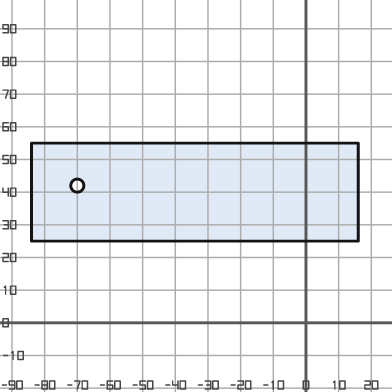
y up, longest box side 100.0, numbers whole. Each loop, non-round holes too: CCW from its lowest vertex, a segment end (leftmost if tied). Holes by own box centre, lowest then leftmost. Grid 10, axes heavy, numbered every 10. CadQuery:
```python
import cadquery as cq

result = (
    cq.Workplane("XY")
    .moveTo(-84.0, 25.0)
    .lineTo(16.0, 25.0)
    .lineTo(16.0, 55.0)
    .lineTo(-84.0, 55.0)
    .close()
    .moveTo(-70.0, 42.0)
    .circle(2.0)
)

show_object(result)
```